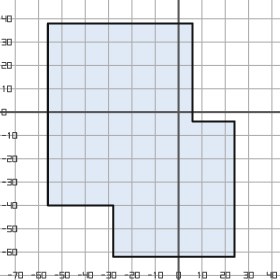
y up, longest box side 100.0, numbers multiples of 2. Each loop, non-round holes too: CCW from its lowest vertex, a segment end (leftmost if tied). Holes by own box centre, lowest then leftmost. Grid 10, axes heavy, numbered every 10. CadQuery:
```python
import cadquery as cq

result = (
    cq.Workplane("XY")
    .moveTo(-28.0, -62.0)
    .lineTo(24.0, -62.0)
    .lineTo(24.0, -4.0)
    .lineTo(6.0, -4.0)
    .lineTo(6.0, 38.0)
    .lineTo(-56.0, 38.0)
    .lineTo(-56.0, -40.0)
    .lineTo(-28.0, -40.0)
    .close()
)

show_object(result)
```